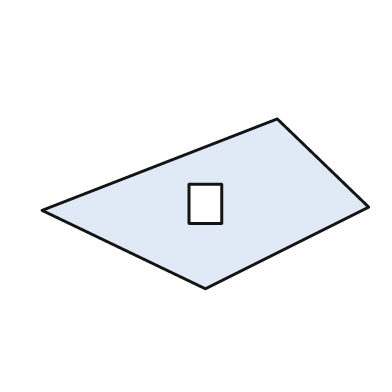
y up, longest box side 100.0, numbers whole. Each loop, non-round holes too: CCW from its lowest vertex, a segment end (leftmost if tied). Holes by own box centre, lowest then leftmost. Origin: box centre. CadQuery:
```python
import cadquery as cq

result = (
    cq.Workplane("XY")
    .moveTo(0.0, -26.0)
    .lineTo(50.0, -1.0)
    .lineTo(22.0, 26.0)
    .lineTo(-50.0, -2.0)
    .close()
    .moveTo(-5.0, -6.0)
    .lineTo(5.0, -6.0)
    .lineTo(5.0, 6.0)
    .lineTo(-5.0, 6.0)
    .close()
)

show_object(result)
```